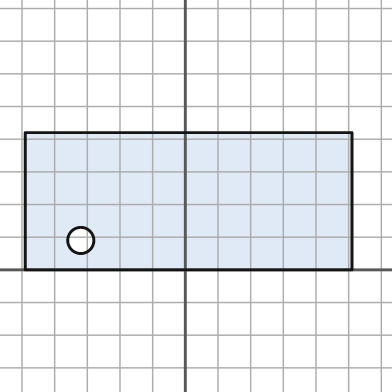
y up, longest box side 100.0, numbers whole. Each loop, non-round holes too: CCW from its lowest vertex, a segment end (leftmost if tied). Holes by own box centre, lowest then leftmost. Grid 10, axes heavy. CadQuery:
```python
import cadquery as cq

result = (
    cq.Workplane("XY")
    .moveTo(-49.0, 0.0)
    .lineTo(51.0, 0.0)
    .lineTo(51.0, 42.0)
    .lineTo(-49.0, 42.0)
    .close()
    .moveTo(-32.0, 9.0)
    .circle(4.0)
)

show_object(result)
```